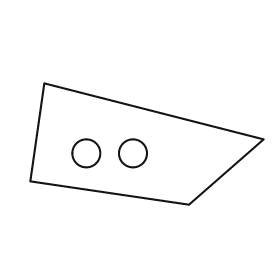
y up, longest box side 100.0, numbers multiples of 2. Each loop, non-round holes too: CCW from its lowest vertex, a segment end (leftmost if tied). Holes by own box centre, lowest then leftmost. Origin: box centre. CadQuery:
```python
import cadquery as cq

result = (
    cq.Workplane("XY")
    .moveTo(18.0, -26.0)
    .lineTo(50.0, 2.0)
    .lineTo(-44.0, 26.0)
    .lineTo(-50.0, -16.0)
    .close()
    .moveTo(-26.0, -4.0)
    .circle(6.0)
    .moveTo(-6.0, -4.0)
    .circle(6.0)
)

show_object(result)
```